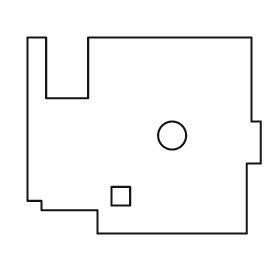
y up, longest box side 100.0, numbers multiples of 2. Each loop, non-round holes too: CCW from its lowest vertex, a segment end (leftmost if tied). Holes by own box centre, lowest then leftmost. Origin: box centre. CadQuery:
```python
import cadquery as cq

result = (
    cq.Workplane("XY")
    .moveTo(-20.0, -42.0)
    .lineTo(44.0, -42.0)
    .lineTo(44.0, -12.0)
    .lineTo(50.0, -12.0)
    .lineTo(50.0, 6.0)
    .lineTo(46.0, 6.0)
    .lineTo(46.0, 42.0)
    .lineTo(-24.0, 42.0)
    .lineTo(-24.0, 16.0)
    .lineTo(-42.0, 16.0)
    .lineTo(-42.0, 42.0)
    .lineTo(-50.0, 42.0)
    .lineTo(-50.0, -28.0)
    .lineTo(-44.0, -28.0)
    .lineTo(-44.0, -32.0)
    .lineTo(-20.0, -32.0)
    .close()
    .moveTo(-14.0, -30.0)
    .lineTo(-6.0, -30.0)
    .lineTo(-6.0, -22.0)
    .lineTo(-14.0, -22.0)
    .close()
    .moveTo(12.0, 0.0)
    .circle(6.0)
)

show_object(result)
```